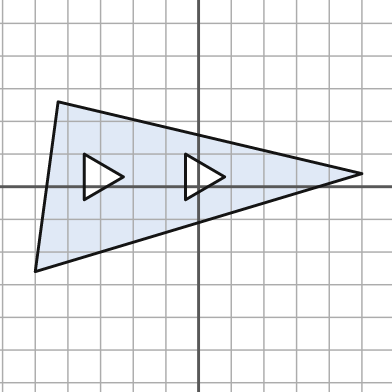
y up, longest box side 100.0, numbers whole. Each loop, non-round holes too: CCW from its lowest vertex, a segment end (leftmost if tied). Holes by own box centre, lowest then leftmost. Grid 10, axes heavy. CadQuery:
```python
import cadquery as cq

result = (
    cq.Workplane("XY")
    .moveTo(-50.0, -26.0)
    .lineTo(50.0, 4.0)
    .lineTo(-43.0, 26.0)
    .close()
    .moveTo(-35.0, -4.0)
    .lineTo(-23.0, 3.0)
    .lineTo(-35.0, 10.0)
    .close()
    .moveTo(-4.0, -4.0)
    .lineTo(8.0, 3.0)
    .lineTo(-4.0, 10.0)
    .close()
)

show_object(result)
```